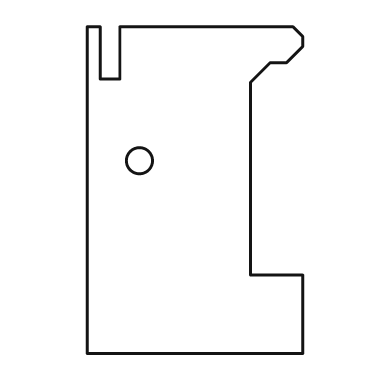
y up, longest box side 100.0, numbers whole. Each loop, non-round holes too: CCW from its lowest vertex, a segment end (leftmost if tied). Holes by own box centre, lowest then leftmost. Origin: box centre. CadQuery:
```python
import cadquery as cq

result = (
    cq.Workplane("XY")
    .moveTo(-33.0, -50.0)
    .lineTo(33.0, -50.0)
    .lineTo(33.0, -26.0)
    .lineTo(17.0, -26.0)
    .lineTo(17.0, 33.0)
    .lineTo(23.0, 39.0)
    .lineTo(28.0, 39.0)
    .lineTo(33.0, 44.0)
    .lineTo(33.0, 47.0)
    .lineTo(30.0, 50.0)
    .lineTo(-23.0, 50.0)
    .lineTo(-23.0, 34.0)
    .lineTo(-29.0, 34.0)
    .lineTo(-29.0, 50.0)
    .lineTo(-33.0, 50.0)
    .close()
    .moveTo(-17.0, 9.0)
    .circle(4.0)
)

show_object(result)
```